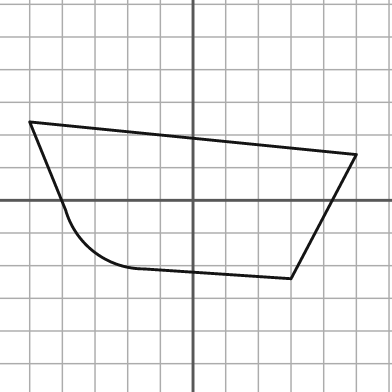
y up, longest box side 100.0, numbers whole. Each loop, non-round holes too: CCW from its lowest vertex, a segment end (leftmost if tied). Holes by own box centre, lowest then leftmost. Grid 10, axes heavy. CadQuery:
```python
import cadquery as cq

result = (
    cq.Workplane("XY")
    .moveTo(30.0, -24.0)
    .lineTo(50.0, 14.0)
    .lineTo(-50.0, 24.0)
    .lineTo(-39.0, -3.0)
    .threePointArc((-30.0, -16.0), (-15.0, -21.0))
    .close()
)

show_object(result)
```